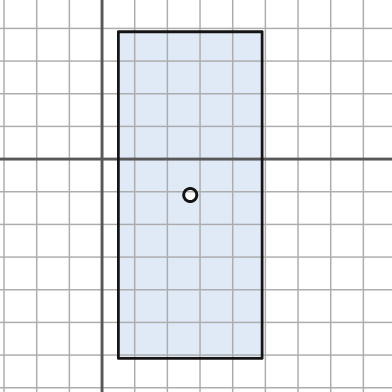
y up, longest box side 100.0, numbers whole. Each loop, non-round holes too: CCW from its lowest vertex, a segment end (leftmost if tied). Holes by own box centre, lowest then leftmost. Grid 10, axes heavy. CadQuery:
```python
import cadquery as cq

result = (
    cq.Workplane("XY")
    .moveTo(5.0, -61.0)
    .lineTo(49.0, -61.0)
    .lineTo(49.0, 39.0)
    .lineTo(5.0, 39.0)
    .close()
    .moveTo(27.0, -11.0)
    .circle(2.0)
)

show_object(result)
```